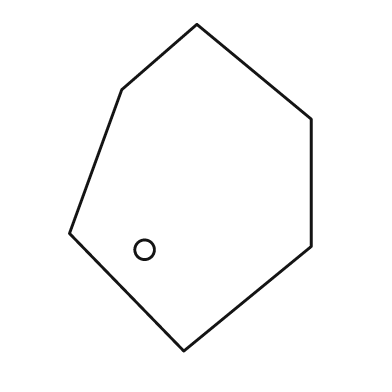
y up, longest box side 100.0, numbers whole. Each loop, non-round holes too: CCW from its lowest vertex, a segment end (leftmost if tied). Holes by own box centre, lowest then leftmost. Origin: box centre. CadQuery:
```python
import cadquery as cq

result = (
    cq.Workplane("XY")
    .moveTo(-2.0, -50.0)
    .lineTo(37.0, -18.0)
    .lineTo(37.0, 21.0)
    .lineTo(2.0, 50.0)
    .lineTo(-21.0, 30.0)
    .lineTo(-37.0, -14.0)
    .close()
    .moveTo(-14.0, -19.0)
    .circle(3.0)
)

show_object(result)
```